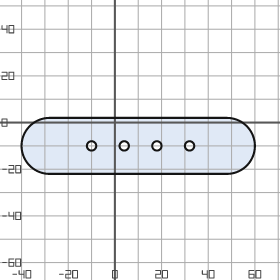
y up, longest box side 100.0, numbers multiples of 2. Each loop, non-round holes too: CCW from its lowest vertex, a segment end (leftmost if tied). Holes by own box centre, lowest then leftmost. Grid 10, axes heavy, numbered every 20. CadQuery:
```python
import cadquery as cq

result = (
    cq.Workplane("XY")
    .moveTo(-28.0, -22.0)
    .lineTo(48.0, -22.0)
    .threePointArc((60.0, -10.0), (48.0, 2.0))
    .lineTo(-28.0, 2.0)
    .threePointArc((-40.0, -10.0), (-28.0, -22.0))
    .close()
    .moveTo(-10.0, -10.0)
    .circle(2.0)
    .moveTo(4.0, -10.0)
    .circle(2.0)
    .moveTo(18.0, -10.0)
    .circle(2.0)
    .moveTo(32.0, -10.0)
    .circle(2.0)
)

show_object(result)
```